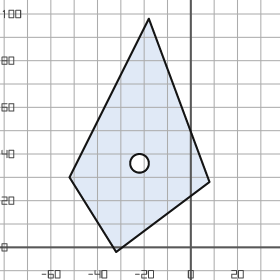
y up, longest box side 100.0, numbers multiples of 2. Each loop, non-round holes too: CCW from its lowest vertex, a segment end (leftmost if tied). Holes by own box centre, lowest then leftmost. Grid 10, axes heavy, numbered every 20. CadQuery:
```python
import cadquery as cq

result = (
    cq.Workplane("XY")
    .moveTo(-32.0, -2.0)
    .lineTo(8.0, 28.0)
    .lineTo(-18.0, 98.0)
    .lineTo(-52.0, 30.0)
    .close()
    .moveTo(-22.0, 36.0)
    .circle(4.0)
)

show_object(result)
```